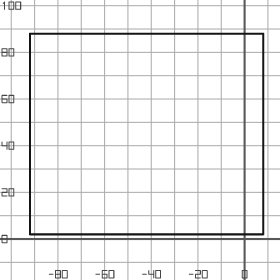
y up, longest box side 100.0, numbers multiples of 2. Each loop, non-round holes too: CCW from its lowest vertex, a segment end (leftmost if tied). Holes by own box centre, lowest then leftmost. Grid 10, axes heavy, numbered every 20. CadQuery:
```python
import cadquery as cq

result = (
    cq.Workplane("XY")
    .moveTo(-92.0, 2.0)
    .lineTo(8.0, 2.0)
    .lineTo(8.0, 88.0)
    .lineTo(-92.0, 88.0)
    .close()
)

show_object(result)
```